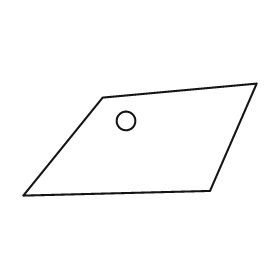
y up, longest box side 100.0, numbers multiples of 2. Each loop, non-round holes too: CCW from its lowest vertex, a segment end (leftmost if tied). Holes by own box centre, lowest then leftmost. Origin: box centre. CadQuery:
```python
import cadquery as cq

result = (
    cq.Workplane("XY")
    .moveTo(-50.0, -24.0)
    .lineTo(30.0, -22.0)
    .lineTo(50.0, 24.0)
    .lineTo(-16.0, 18.0)
    .close()
    .moveTo(-6.0, 8.0)
    .circle(4.0)
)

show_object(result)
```